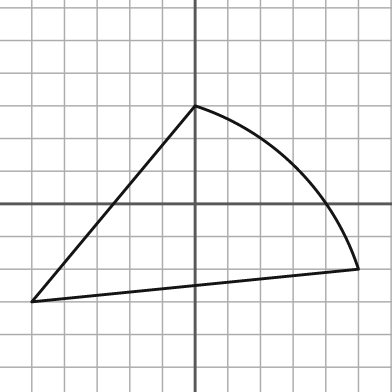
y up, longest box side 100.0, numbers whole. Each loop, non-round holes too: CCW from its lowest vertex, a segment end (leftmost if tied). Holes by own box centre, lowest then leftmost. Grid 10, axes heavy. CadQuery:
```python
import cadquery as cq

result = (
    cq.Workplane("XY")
    .moveTo(-50.0, -30.0)
    .lineTo(50.0, -20.0)
    .threePointArc((31.0, 11.0), (0.0, 30.0))
    .close()
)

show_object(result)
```